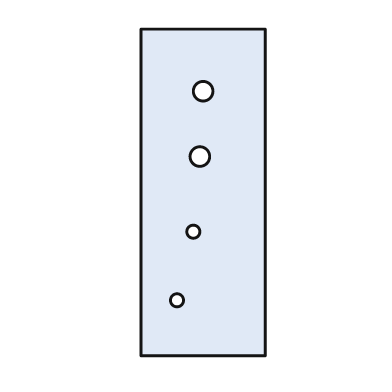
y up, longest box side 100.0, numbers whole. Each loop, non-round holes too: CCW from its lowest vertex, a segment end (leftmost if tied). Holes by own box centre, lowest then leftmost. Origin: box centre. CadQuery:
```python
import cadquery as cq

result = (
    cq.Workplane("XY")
    .moveTo(-19.0, -50.0)
    .lineTo(19.0, -50.0)
    .lineTo(19.0, 50.0)
    .lineTo(-19.0, 50.0)
    .close()
    .moveTo(-8.0, -33.0)
    .circle(2.0)
    .moveTo(-3.0, -12.0)
    .circle(2.0)
    .moveTo(-1.0, 11.0)
    .circle(3.0)
    .moveTo(0.0, 31.0)
    .circle(3.0)
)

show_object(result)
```